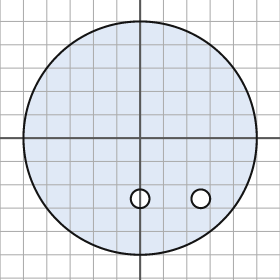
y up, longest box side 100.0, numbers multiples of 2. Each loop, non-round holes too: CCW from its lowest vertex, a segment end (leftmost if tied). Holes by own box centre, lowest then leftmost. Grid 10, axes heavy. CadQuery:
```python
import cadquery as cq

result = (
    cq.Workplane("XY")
    .moveTo(0.0, 0.0)
    .circle(50.0)
    .moveTo(0.0, -26.0)
    .circle(4.0)
    .moveTo(26.0, -26.0)
    .circle(4.0)
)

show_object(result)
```